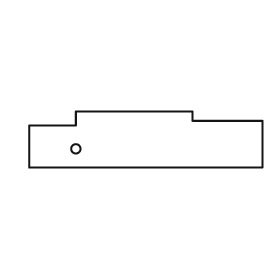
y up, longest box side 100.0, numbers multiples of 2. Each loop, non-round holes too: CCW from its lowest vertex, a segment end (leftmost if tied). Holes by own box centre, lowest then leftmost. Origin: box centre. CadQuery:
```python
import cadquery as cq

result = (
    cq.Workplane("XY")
    .moveTo(-50.0, -12.0)
    .lineTo(50.0, -12.0)
    .lineTo(50.0, 8.0)
    .lineTo(20.0, 8.0)
    .lineTo(20.0, 12.0)
    .lineTo(-30.0, 12.0)
    .lineTo(-30.0, 6.0)
    .lineTo(-50.0, 6.0)
    .close()
    .moveTo(-30.0, -4.0)
    .circle(2.0)
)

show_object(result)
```